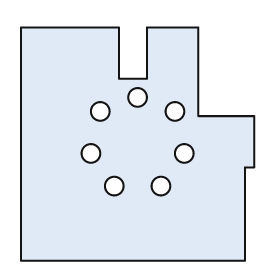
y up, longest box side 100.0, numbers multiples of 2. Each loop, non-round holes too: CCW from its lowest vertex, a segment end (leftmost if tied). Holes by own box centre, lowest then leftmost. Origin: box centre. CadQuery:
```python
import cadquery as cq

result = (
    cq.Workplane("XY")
    .moveTo(-50.0, -50.0)
    .lineTo(46.0, -50.0)
    .lineTo(46.0, -10.0)
    .lineTo(50.0, -10.0)
    .lineTo(50.0, 12.0)
    .lineTo(26.0, 12.0)
    .lineTo(26.0, 50.0)
    .lineTo(4.0, 50.0)
    .lineTo(4.0, 28.0)
    .lineTo(-8.0, 28.0)
    .lineTo(-8.0, 50.0)
    .lineTo(-50.0, 50.0)
    .close()
    .moveTo(-10.0, -18.0)
    .circle(4.0)
    .moveTo(10.0, -18.0)
    .circle(4.0)
    .moveTo(-20.0, -4.0)
    .circle(4.0)
    .moveTo(20.0, -4.0)
    .circle(4.0)
    .moveTo(-16.0, 14.0)
    .circle(4.0)
    .moveTo(16.0, 14.0)
    .circle(4.0)
    .moveTo(0.0, 20.0)
    .circle(4.0)
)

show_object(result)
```